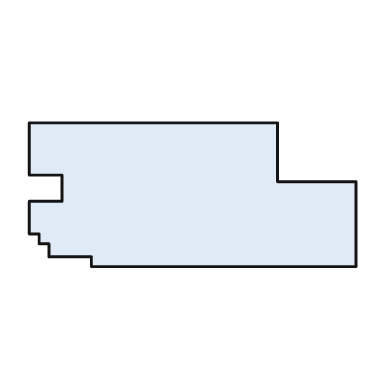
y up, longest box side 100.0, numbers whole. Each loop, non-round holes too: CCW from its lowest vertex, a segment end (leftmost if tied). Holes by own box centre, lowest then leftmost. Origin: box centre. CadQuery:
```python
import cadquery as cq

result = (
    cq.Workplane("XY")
    .moveTo(-31.0, -22.0)
    .lineTo(50.0, -22.0)
    .lineTo(50.0, 4.0)
    .lineTo(26.0, 4.0)
    .lineTo(26.0, 22.0)
    .lineTo(-50.0, 22.0)
    .lineTo(-50.0, 6.0)
    .lineTo(-40.0, 6.0)
    .lineTo(-40.0, -2.0)
    .lineTo(-50.0, -2.0)
    .lineTo(-50.0, -12.0)
    .lineTo(-47.0, -12.0)
    .lineTo(-47.0, -15.0)
    .lineTo(-44.0, -15.0)
    .lineTo(-44.0, -19.0)
    .lineTo(-31.0, -19.0)
    .close()
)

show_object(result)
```